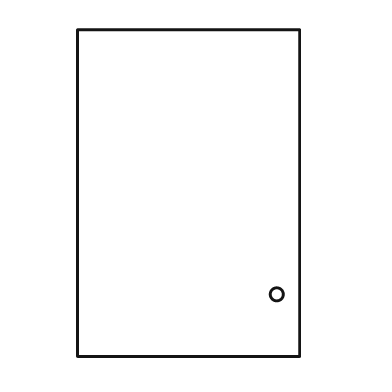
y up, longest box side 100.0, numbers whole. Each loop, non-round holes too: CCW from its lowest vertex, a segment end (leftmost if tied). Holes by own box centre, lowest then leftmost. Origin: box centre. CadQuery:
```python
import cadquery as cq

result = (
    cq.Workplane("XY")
    .moveTo(-34.0, -50.0)
    .lineTo(34.0, -50.0)
    .lineTo(34.0, 50.0)
    .lineTo(-34.0, 50.0)
    .close()
    .moveTo(27.0, -31.0)
    .circle(2.0)
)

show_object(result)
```